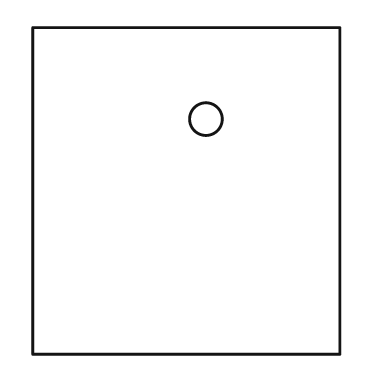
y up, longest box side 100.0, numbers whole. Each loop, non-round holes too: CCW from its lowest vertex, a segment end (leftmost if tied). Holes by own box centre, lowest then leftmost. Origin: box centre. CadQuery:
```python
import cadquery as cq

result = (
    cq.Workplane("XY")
    .moveTo(-47.0, -50.0)
    .lineTo(47.0, -50.0)
    .lineTo(47.0, 50.0)
    .lineTo(-47.0, 50.0)
    .close()
    .moveTo(6.0, 22.0)
    .circle(5.0)
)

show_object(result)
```